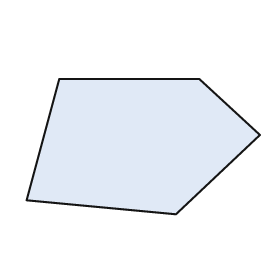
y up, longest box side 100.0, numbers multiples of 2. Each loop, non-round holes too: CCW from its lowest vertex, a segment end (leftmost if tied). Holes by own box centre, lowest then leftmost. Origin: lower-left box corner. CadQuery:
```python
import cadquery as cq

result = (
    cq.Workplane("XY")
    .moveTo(64.0, 0.0)
    .lineTo(100.0, 34.0)
    .lineTo(74.0, 58.0)
    .lineTo(14.0, 58.0)
    .lineTo(0.0, 6.0)
    .close()
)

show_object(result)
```